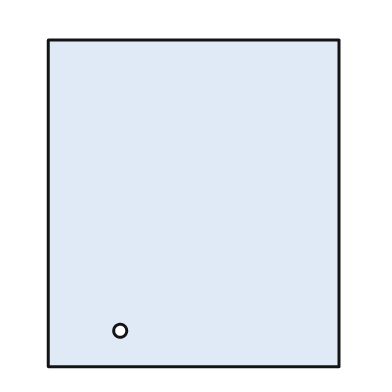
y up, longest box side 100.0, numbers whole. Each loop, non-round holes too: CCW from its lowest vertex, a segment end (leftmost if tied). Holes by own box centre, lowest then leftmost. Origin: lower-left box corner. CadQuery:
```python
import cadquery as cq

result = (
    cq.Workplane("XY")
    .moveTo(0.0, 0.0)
    .lineTo(89.0, 0.0)
    .lineTo(89.0, 100.0)
    .lineTo(0.0, 100.0)
    .close()
    .moveTo(22.0, 11.0)
    .circle(2.0)
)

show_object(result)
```